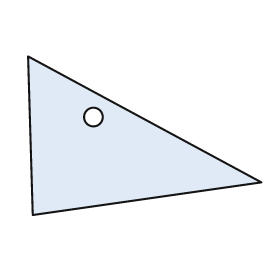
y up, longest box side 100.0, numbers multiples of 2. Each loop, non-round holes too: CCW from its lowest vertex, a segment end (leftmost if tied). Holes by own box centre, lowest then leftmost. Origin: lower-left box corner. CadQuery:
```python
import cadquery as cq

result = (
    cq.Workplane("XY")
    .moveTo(2.0, 0.0)
    .lineTo(100.0, 14.0)
    .lineTo(0.0, 68.0)
    .close()
    .moveTo(28.0, 42.0)
    .circle(4.0)
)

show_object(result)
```